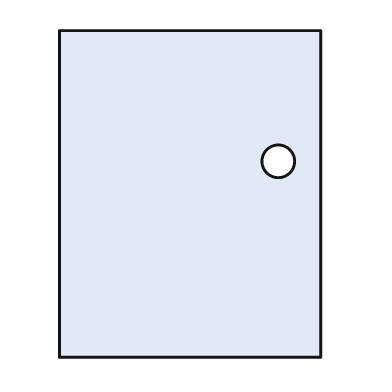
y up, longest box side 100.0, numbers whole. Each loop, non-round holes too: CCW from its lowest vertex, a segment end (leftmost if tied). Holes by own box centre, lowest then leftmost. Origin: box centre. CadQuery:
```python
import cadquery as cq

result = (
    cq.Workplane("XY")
    .moveTo(-40.0, -50.0)
    .lineTo(40.0, -50.0)
    .lineTo(40.0, 50.0)
    .lineTo(-40.0, 50.0)
    .close()
    .moveTo(27.0, 10.0)
    .circle(5.0)
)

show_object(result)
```